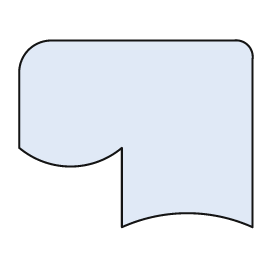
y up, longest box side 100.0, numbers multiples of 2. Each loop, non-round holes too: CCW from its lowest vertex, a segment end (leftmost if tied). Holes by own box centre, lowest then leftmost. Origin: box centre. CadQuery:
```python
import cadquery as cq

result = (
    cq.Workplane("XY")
    .moveTo(-6.0, -40.0)
    .threePointArc((22.0, -34.0), (50.0, -40.0))
    .lineTo(50.0, 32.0)
    .threePointArc((48.0, 38.0), (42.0, 40.0))
    .lineTo(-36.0, 40.0)
    .threePointArc((-46.0, 36.0), (-50.0, 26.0))
    .lineTo(-50.0, -6.0)
    .threePointArc((-28.0, -14.0), (-6.0, -6.0))
    .close()
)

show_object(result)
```